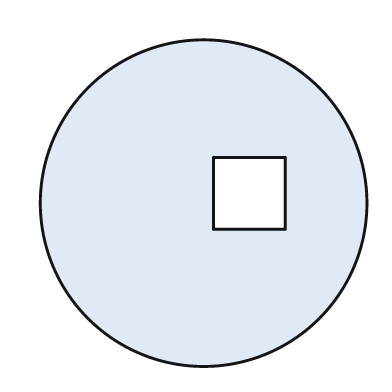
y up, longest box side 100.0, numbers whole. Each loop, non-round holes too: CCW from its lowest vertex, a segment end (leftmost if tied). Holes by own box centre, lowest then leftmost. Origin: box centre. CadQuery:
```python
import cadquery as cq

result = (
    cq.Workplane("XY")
    .moveTo(0.0, 0.0)
    .circle(50.0)
    .moveTo(3.0, -8.0)
    .lineTo(25.0, -8.0)
    .lineTo(25.0, 14.0)
    .lineTo(3.0, 14.0)
    .close()
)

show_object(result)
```